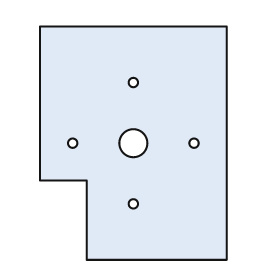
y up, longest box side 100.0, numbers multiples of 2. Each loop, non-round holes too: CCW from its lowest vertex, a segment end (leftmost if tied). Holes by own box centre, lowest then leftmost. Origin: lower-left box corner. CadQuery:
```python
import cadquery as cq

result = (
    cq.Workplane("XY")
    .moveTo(20.0, 0.0)
    .lineTo(80.0, 0.0)
    .lineTo(80.0, 100.0)
    .lineTo(0.0, 100.0)
    .lineTo(0.0, 34.0)
    .lineTo(20.0, 34.0)
    .close()
    .moveTo(40.0, 24.0)
    .circle(2.0)
    .moveTo(14.0, 50.0)
    .circle(2.0)
    .moveTo(40.0, 50.0)
    .circle(6.0)
    .moveTo(66.0, 50.0)
    .circle(2.0)
    .moveTo(40.0, 76.0)
    .circle(2.0)
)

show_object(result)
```